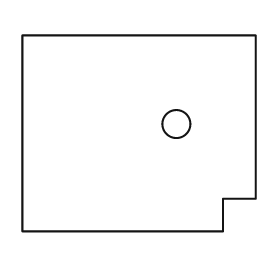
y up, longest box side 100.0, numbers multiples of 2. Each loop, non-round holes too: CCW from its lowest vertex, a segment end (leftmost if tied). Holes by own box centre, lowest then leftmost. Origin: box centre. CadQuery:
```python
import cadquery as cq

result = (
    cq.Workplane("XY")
    .moveTo(-50.0, -42.0)
    .lineTo(36.0, -42.0)
    .lineTo(36.0, -28.0)
    .lineTo(50.0, -28.0)
    .lineTo(50.0, 42.0)
    .lineTo(-50.0, 42.0)
    .close()
    .moveTo(16.0, 4.0)
    .circle(6.0)
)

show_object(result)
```